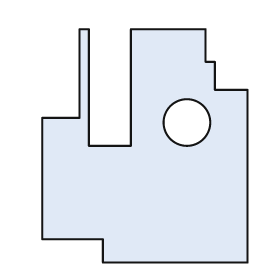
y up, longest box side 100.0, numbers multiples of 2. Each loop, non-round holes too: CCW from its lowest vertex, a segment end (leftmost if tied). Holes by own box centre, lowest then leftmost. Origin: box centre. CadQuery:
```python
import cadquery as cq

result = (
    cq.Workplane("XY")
    .moveTo(-18.0, -50.0)
    .lineTo(44.0, -50.0)
    .lineTo(44.0, 24.0)
    .lineTo(30.0, 24.0)
    .lineTo(30.0, 36.0)
    .lineTo(26.0, 36.0)
    .lineTo(26.0, 50.0)
    .lineTo(-6.0, 50.0)
    .lineTo(-6.0, 0.0)
    .lineTo(-24.0, 0.0)
    .lineTo(-24.0, 50.0)
    .lineTo(-28.0, 50.0)
    .lineTo(-28.0, 12.0)
    .lineTo(-44.0, 12.0)
    .lineTo(-44.0, -40.0)
    .lineTo(-18.0, -40.0)
    .close()
    .moveTo(18.0, 10.0)
    .circle(10.0)
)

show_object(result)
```